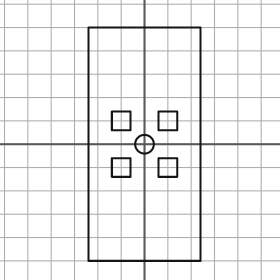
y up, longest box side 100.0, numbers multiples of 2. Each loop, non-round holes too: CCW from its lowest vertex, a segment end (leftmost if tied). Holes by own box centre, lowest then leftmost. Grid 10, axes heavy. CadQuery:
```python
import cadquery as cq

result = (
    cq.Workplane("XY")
    .moveTo(-24.0, -50.0)
    .lineTo(24.0, -50.0)
    .lineTo(24.0, 50.0)
    .lineTo(-24.0, 50.0)
    .close()
    .moveTo(-14.0, -14.0)
    .lineTo(-6.0, -14.0)
    .lineTo(-6.0, -6.0)
    .lineTo(-14.0, -6.0)
    .close()
    .moveTo(6.0, -14.0)
    .lineTo(14.0, -14.0)
    .lineTo(14.0, -6.0)
    .lineTo(6.0, -6.0)
    .close()
    .moveTo(0.0, 0.0)
    .circle(4.0)
    .moveTo(-14.0, 6.0)
    .lineTo(-6.0, 6.0)
    .lineTo(-6.0, 14.0)
    .lineTo(-14.0, 14.0)
    .close()
    .moveTo(6.0, 6.0)
    .lineTo(14.0, 6.0)
    .lineTo(14.0, 14.0)
    .lineTo(6.0, 14.0)
    .close()
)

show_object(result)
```